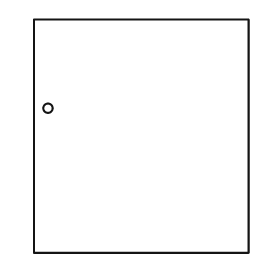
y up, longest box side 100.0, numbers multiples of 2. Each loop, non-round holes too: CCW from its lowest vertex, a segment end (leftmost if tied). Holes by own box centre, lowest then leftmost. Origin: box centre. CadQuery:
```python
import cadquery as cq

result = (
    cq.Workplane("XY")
    .moveTo(-46.0, -50.0)
    .lineTo(46.0, -50.0)
    .lineTo(46.0, 50.0)
    .lineTo(-46.0, 50.0)
    .close()
    .moveTo(-40.0, 12.0)
    .circle(2.0)
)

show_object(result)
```